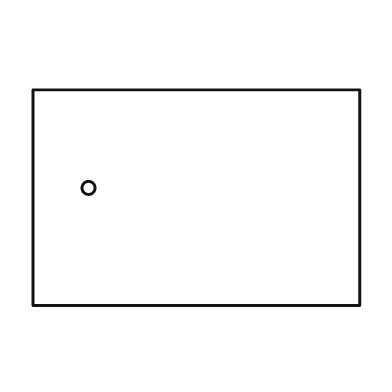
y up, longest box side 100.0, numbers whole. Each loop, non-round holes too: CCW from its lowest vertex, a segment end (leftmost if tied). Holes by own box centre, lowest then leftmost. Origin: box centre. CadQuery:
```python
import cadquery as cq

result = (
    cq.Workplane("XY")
    .moveTo(-50.0, -33.0)
    .lineTo(50.0, -33.0)
    .lineTo(50.0, 33.0)
    .lineTo(-50.0, 33.0)
    .close()
    .moveTo(-33.0, 3.0)
    .circle(2.0)
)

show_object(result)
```